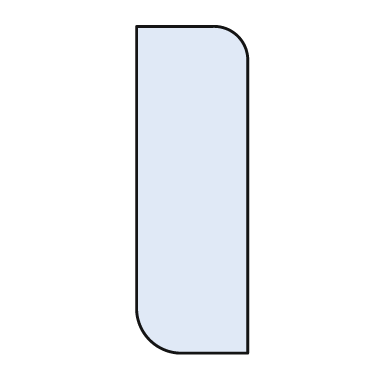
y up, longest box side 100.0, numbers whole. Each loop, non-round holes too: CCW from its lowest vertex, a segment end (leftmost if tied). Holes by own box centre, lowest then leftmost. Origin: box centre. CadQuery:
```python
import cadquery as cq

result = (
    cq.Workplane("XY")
    .moveTo(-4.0, -50.0)
    .lineTo(17.0, -50.0)
    .lineTo(17.0, 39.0)
    .threePointArc((14.0, 47.0), (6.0, 50.0))
    .lineTo(-17.0, 50.0)
    .lineTo(-17.0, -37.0)
    .threePointArc((-13.0, -46.0), (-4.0, -50.0))
    .close()
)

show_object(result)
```